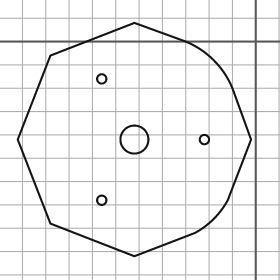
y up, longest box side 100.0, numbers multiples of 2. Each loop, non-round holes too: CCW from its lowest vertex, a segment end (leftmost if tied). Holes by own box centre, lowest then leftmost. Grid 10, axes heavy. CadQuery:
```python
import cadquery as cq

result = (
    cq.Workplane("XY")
    .moveTo(-52.0, -92.0)
    .lineTo(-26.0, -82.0)
    .threePointArc((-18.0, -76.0), (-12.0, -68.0))
    .lineTo(-2.0, -42.0)
    .lineTo(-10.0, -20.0)
    .threePointArc((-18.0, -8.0), (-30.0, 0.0))
    .lineTo(-52.0, 8.0)
    .lineTo(-88.0, -6.0)
    .lineTo(-102.0, -42.0)
    .lineTo(-88.0, -78.0)
    .close()
    .moveTo(-66.0, -68.0)
    .circle(2.0)
    .moveTo(-52.0, -42.0)
    .circle(6.0)
    .moveTo(-22.0, -42.0)
    .circle(2.0)
    .moveTo(-66.0, -16.0)
    .circle(2.0)
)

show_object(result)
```